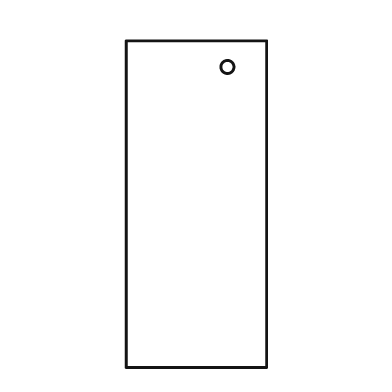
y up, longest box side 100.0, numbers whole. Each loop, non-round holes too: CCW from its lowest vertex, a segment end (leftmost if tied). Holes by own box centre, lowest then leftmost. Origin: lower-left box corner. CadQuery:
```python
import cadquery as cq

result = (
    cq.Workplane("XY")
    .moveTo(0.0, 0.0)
    .lineTo(43.0, 0.0)
    .lineTo(43.0, 100.0)
    .lineTo(0.0, 100.0)
    .close()
    .moveTo(31.0, 92.0)
    .circle(2.0)
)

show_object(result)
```